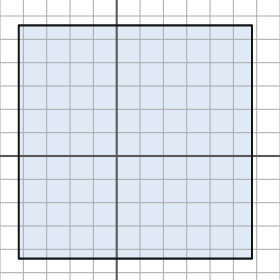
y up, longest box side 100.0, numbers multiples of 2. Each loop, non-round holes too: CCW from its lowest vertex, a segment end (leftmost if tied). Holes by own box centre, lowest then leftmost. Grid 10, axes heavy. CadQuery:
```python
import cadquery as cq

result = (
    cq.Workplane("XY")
    .moveTo(-42.0, -44.0)
    .lineTo(58.0, -44.0)
    .lineTo(58.0, 56.0)
    .lineTo(-42.0, 56.0)
    .close()
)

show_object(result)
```